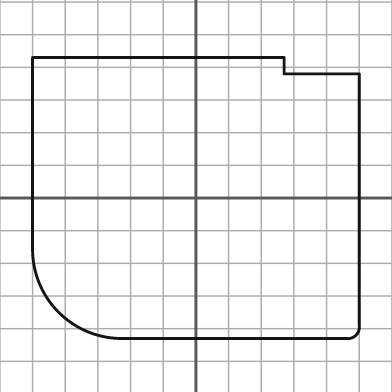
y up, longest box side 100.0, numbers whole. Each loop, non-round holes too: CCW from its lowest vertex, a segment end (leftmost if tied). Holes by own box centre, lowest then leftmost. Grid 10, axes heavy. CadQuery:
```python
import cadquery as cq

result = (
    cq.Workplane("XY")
    .moveTo(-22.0, -43.0)
    .lineTo(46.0, -43.0)
    .threePointArc((49.0, -42.0), (50.0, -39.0))
    .lineTo(50.0, 38.0)
    .lineTo(27.0, 38.0)
    .lineTo(27.0, 43.0)
    .lineTo(-50.0, 43.0)
    .lineTo(-50.0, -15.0)
    .threePointArc((-42.0, -35.0), (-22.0, -43.0))
    .close()
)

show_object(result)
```